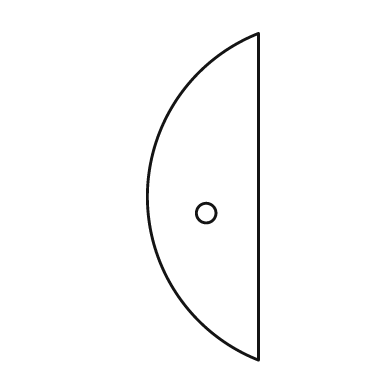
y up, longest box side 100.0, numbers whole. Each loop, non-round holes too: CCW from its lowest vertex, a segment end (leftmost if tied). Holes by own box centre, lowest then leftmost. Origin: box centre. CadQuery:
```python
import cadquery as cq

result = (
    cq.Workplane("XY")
    .moveTo(17.0, -50.0)
    .lineTo(17.0, 50.0)
    .threePointArc((-17.0, 0.0), (17.0, -50.0))
    .close()
    .moveTo(1.0, -5.0)
    .circle(3.0)
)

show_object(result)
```